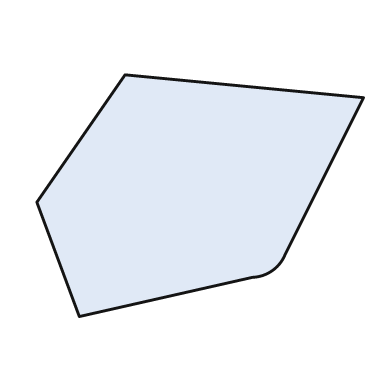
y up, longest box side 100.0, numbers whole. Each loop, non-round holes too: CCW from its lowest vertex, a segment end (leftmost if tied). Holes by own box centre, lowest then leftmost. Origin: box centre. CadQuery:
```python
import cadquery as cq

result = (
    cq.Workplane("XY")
    .moveTo(-37.0, -37.0)
    .lineTo(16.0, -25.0)
    .threePointArc((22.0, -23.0), (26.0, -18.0))
    .lineTo(50.0, 30.0)
    .lineTo(-23.0, 37.0)
    .lineTo(-50.0, -2.0)
    .close()
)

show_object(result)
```